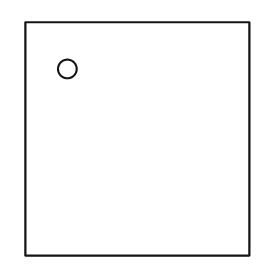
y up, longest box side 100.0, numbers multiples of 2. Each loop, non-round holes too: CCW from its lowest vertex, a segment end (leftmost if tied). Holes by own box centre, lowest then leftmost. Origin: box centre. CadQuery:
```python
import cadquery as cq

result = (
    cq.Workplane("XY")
    .moveTo(-48.0, -50.0)
    .lineTo(48.0, -50.0)
    .lineTo(48.0, 50.0)
    .lineTo(-48.0, 50.0)
    .close()
    .moveTo(-30.0, 30.0)
    .circle(4.0)
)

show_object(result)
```